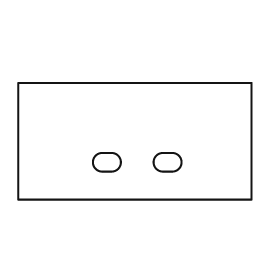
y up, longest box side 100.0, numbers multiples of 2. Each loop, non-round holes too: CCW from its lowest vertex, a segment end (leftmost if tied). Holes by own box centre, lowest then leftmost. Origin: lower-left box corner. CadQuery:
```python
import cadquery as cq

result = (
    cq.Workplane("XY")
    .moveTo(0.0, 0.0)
    .lineTo(100.0, 0.0)
    .lineTo(100.0, 50.0)
    .lineTo(0.0, 50.0)
    .close()
    .moveTo(36.0, 12.0)
    .lineTo(40.0, 12.0)
    .threePointArc((44.0, 16.0), (40.0, 20.0))
    .lineTo(36.0, 20.0)
    .threePointArc((32.0, 16.0), (36.0, 12.0))
    .close()
    .moveTo(62.0, 12.0)
    .lineTo(66.0, 12.0)
    .threePointArc((70.0, 16.0), (66.0, 20.0))
    .lineTo(62.0, 20.0)
    .threePointArc((58.0, 16.0), (62.0, 12.0))
    .close()
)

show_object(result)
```